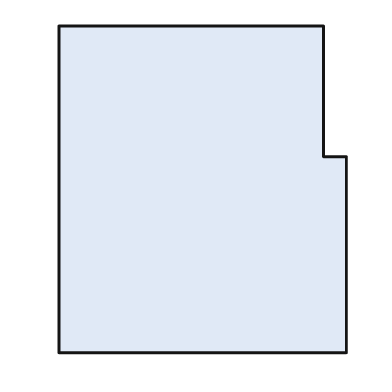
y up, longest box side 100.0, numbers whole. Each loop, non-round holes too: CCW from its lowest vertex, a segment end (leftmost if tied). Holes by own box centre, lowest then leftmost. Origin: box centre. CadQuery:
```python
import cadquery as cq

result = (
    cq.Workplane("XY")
    .moveTo(-44.0, -50.0)
    .lineTo(44.0, -50.0)
    .lineTo(44.0, 10.0)
    .lineTo(37.0, 10.0)
    .lineTo(37.0, 50.0)
    .lineTo(-44.0, 50.0)
    .close()
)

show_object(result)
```